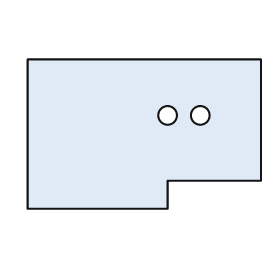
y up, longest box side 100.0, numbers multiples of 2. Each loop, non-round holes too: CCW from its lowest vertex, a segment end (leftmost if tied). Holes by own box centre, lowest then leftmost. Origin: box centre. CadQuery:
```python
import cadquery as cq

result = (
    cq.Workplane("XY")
    .moveTo(-50.0, -32.0)
    .lineTo(10.0, -32.0)
    .lineTo(10.0, -20.0)
    .lineTo(50.0, -20.0)
    .lineTo(50.0, 32.0)
    .lineTo(-50.0, 32.0)
    .close()
    .moveTo(10.0, 8.0)
    .circle(4.0)
    .moveTo(24.0, 8.0)
    .circle(4.0)
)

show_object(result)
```